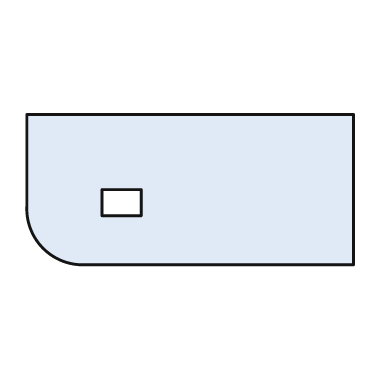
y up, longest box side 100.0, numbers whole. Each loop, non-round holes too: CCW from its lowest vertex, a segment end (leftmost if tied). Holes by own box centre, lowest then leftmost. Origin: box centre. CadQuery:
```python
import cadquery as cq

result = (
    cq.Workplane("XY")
    .moveTo(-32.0, -23.0)
    .lineTo(50.0, -23.0)
    .lineTo(50.0, 23.0)
    .lineTo(-50.0, 23.0)
    .lineTo(-50.0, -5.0)
    .threePointArc((-45.0, -18.0), (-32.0, -23.0))
    .close()
    .moveTo(-27.0, -8.0)
    .lineTo(-15.0, -8.0)
    .lineTo(-15.0, 0.0)
    .lineTo(-27.0, 0.0)
    .close()
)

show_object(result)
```